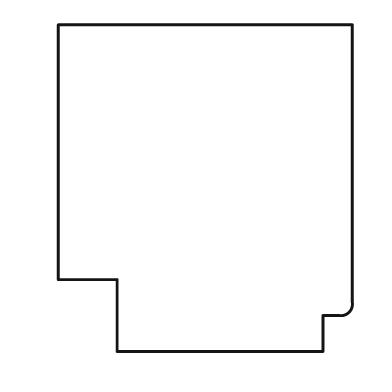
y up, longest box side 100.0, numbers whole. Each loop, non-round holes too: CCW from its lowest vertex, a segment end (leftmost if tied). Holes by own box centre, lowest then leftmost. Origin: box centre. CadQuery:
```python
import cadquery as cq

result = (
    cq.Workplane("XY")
    .moveTo(-27.0, -50.0)
    .lineTo(36.0, -50.0)
    .lineTo(36.0, -39.0)
    .lineTo(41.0, -39.0)
    .threePointArc((44.0, -38.0), (45.0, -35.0))
    .lineTo(45.0, 50.0)
    .lineTo(-45.0, 50.0)
    .lineTo(-45.0, -28.0)
    .lineTo(-27.0, -28.0)
    .close()
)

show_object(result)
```